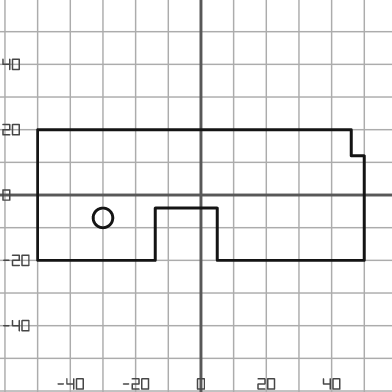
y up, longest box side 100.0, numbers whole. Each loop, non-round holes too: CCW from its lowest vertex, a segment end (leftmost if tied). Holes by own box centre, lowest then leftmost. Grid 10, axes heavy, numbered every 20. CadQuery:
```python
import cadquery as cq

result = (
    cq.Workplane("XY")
    .moveTo(-50.0, -20.0)
    .lineTo(-14.0, -20.0)
    .lineTo(-14.0, -4.0)
    .lineTo(5.0, -4.0)
    .lineTo(5.0, -20.0)
    .lineTo(50.0, -20.0)
    .lineTo(50.0, 12.0)
    .lineTo(46.0, 12.0)
    .lineTo(46.0, 20.0)
    .lineTo(-50.0, 20.0)
    .close()
    .moveTo(-30.0, -7.0)
    .circle(3.0)
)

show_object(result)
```